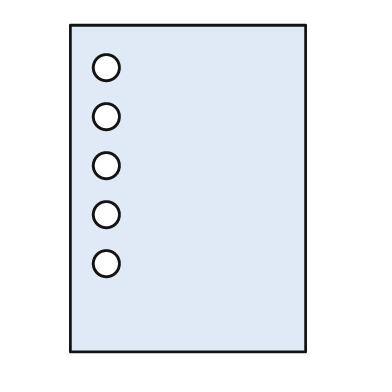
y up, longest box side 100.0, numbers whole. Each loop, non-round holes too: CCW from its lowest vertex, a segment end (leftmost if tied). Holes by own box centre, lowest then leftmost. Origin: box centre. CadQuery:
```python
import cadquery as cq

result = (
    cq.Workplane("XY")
    .moveTo(-36.0, -50.0)
    .lineTo(36.0, -50.0)
    .lineTo(36.0, 50.0)
    .lineTo(-36.0, 50.0)
    .close()
    .moveTo(-25.0, -23.0)
    .circle(4.0)
    .moveTo(-25.0, -8.0)
    .circle(4.0)
    .moveTo(-25.0, 7.0)
    .circle(4.0)
    .moveTo(-25.0, 22.0)
    .circle(4.0)
    .moveTo(-25.0, 37.0)
    .circle(4.0)
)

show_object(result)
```